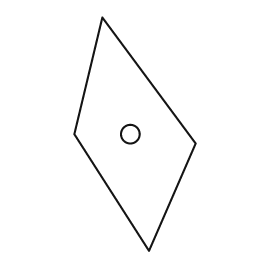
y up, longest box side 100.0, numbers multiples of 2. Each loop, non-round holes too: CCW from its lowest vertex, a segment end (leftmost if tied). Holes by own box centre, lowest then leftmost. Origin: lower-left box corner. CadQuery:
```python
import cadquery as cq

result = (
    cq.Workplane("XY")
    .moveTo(32.0, 0.0)
    .lineTo(52.0, 46.0)
    .lineTo(12.0, 100.0)
    .lineTo(0.0, 50.0)
    .close()
    .moveTo(24.0, 50.0)
    .circle(4.0)
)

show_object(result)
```